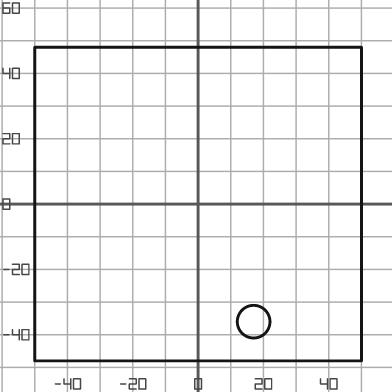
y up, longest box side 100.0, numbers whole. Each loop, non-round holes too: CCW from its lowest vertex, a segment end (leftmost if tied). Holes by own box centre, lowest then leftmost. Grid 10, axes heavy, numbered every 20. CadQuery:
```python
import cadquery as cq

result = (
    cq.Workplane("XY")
    .moveTo(-50.0, -48.0)
    .lineTo(50.0, -48.0)
    .lineTo(50.0, 48.0)
    .lineTo(-50.0, 48.0)
    .close()
    .moveTo(17.0, -36.0)
    .circle(5.0)
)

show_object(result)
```